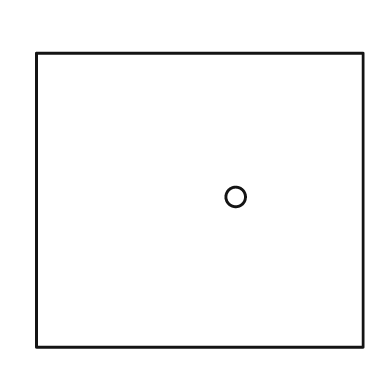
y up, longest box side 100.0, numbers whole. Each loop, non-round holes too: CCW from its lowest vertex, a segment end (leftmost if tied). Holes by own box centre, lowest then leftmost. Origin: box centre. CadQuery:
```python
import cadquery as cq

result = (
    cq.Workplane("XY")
    .moveTo(-50.0, -45.0)
    .lineTo(50.0, -45.0)
    .lineTo(50.0, 45.0)
    .lineTo(-50.0, 45.0)
    .close()
    .moveTo(11.0, 1.0)
    .circle(3.0)
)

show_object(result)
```